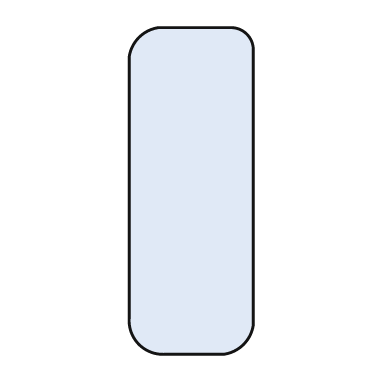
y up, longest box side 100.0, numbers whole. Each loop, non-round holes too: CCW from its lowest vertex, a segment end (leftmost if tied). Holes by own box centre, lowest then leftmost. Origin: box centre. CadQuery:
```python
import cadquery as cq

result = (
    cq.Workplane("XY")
    .moveTo(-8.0, -50.0)
    .lineTo(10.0, -50.0)
    .threePointArc((16.0, -47.0), (19.0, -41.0))
    .lineTo(19.0, 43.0)
    .threePointArc((17.0, 48.0), (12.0, 50.0))
    .lineTo(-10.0, 50.0)
    .threePointArc((-16.0, 47.0), (-19.0, 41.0))
    .lineTo(-19.0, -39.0)
    .threePointArc((-16.0, -47.0), (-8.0, -50.0))
    .close()
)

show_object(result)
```